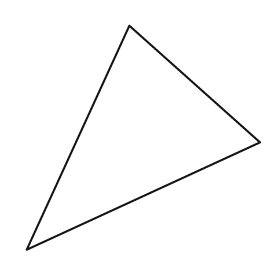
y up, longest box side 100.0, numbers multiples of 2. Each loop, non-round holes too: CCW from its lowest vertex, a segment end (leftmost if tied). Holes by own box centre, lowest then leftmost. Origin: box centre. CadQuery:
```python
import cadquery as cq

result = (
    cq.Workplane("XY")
    .moveTo(-50.0, -48.0)
    .lineTo(50.0, -2.0)
    .lineTo(-6.0, 48.0)
    .close()
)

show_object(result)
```